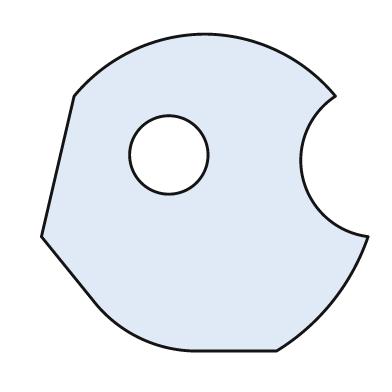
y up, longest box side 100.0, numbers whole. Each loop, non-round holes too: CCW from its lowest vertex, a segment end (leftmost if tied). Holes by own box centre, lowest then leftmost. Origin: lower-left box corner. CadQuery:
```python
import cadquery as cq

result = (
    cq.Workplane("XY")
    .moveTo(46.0, 0.0)
    .lineTo(72.0, 0.0)
    .threePointArc((89.0, 15.0), (100.0, 35.0))
    .threePointArc((80.0, 53.0), (90.0, 78.0))
    .threePointArc((72.0, 92.0), (50.0, 97.0))
    .threePointArc((28.0, 92.0), (10.0, 78.0))
    .lineTo(0.0, 35.0)
    .lineTo(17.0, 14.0)
    .threePointArc((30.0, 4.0), (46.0, 0.0))
    .close()
    .moveTo(39.0, 60.0)
    .circle(12.0)
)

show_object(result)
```